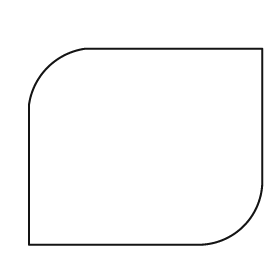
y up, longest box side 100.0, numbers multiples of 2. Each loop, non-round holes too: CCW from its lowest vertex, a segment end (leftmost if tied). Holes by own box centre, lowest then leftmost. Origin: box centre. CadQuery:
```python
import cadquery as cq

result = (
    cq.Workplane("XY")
    .moveTo(-50.0, -42.0)
    .lineTo(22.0, -42.0)
    .threePointArc((42.0, -34.0), (50.0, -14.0))
    .lineTo(50.0, 42.0)
    .lineTo(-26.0, 42.0)
    .threePointArc((-42.0, 34.0), (-50.0, 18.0))
    .close()
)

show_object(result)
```